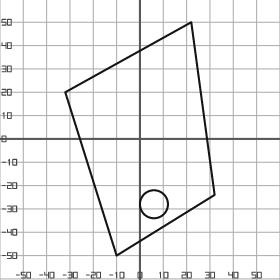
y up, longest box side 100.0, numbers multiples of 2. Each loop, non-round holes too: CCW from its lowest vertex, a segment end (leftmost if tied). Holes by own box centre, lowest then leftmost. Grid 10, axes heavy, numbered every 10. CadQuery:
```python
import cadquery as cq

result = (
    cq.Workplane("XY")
    .moveTo(-10.0, -50.0)
    .lineTo(32.0, -24.0)
    .lineTo(22.0, 50.0)
    .lineTo(-32.0, 20.0)
    .close()
    .moveTo(6.0, -28.0)
    .circle(6.0)
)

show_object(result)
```